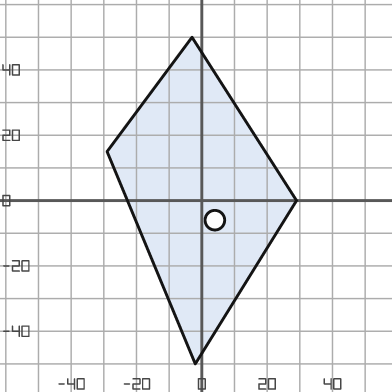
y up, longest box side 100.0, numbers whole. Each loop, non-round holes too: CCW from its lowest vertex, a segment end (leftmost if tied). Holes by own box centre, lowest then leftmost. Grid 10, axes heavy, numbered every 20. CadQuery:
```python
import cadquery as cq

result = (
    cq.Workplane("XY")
    .moveTo(-2.0, -50.0)
    .lineTo(29.0, 0.0)
    .lineTo(-3.0, 50.0)
    .lineTo(-29.0, 15.0)
    .close()
    .moveTo(4.0, -6.0)
    .circle(3.0)
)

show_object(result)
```